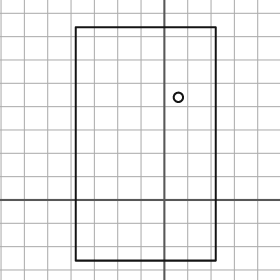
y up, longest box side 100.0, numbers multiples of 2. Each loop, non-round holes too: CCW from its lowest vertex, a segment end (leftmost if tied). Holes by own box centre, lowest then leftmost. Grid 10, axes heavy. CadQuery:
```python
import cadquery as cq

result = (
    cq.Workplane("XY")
    .moveTo(-38.0, -26.0)
    .lineTo(22.0, -26.0)
    .lineTo(22.0, 74.0)
    .lineTo(-38.0, 74.0)
    .close()
    .moveTo(6.0, 44.0)
    .circle(2.0)
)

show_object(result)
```